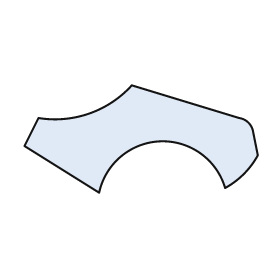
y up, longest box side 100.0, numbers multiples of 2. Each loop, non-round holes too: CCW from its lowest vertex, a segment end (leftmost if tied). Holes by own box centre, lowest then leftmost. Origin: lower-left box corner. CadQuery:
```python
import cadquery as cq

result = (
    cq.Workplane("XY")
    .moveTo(32.0, 0.0)
    .threePointArc((58.0, 22.0), (86.0, 2.0))
    .threePointArc((94.0, 8.0), (100.0, 16.0))
    .lineTo(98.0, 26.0)
    .threePointArc((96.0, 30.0), (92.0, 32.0))
    .lineTo(46.0, 46.0)
    .threePointArc((28.0, 34.0), (6.0, 32.0))
    .lineTo(0.0, 20.0)
    .close()
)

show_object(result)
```